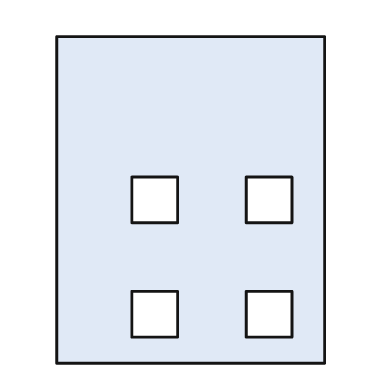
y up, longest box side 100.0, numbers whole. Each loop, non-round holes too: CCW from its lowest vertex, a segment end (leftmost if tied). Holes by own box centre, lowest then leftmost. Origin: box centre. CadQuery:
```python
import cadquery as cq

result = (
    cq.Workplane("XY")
    .moveTo(-41.0, -50.0)
    .lineTo(41.0, -50.0)
    .lineTo(41.0, 50.0)
    .lineTo(-41.0, 50.0)
    .close()
    .moveTo(-18.0, -42.0)
    .lineTo(-4.0, -42.0)
    .lineTo(-4.0, -28.0)
    .lineTo(-18.0, -28.0)
    .close()
    .moveTo(17.0, -42.0)
    .lineTo(31.0, -42.0)
    .lineTo(31.0, -28.0)
    .lineTo(17.0, -28.0)
    .close()
    .moveTo(-18.0, -7.0)
    .lineTo(-4.0, -7.0)
    .lineTo(-4.0, 7.0)
    .lineTo(-18.0, 7.0)
    .close()
    .moveTo(17.0, -7.0)
    .lineTo(31.0, -7.0)
    .lineTo(31.0, 7.0)
    .lineTo(17.0, 7.0)
    .close()
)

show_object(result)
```